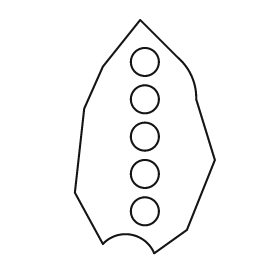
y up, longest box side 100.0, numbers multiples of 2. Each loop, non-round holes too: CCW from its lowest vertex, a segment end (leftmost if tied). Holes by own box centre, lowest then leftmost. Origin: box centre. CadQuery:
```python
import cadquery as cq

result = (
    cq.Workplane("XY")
    .moveTo(4.0, -50.0)
    .lineTo(18.0, -40.0)
    .lineTo(30.0, -10.0)
    .lineTo(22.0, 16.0)
    .threePointArc((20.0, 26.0), (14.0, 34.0))
    .lineTo(-2.0, 50.0)
    .lineTo(-18.0, 30.0)
    .lineTo(-26.0, 12.0)
    .lineTo(-30.0, -24.0)
    .lineTo(-18.0, -46.0)
    .threePointArc((-6.0, -42.0), (4.0, -50.0))
    .close()
    .moveTo(0.0, -32.0)
    .circle(6.0)
    .moveTo(0.0, -16.0)
    .circle(6.0)
    .moveTo(0.0, 0.0)
    .circle(6.0)
    .moveTo(0.0, 16.0)
    .circle(6.0)
    .moveTo(0.0, 32.0)
    .circle(6.0)
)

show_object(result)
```